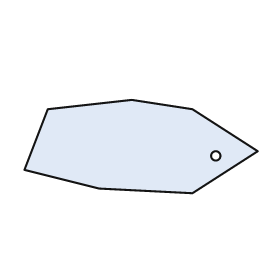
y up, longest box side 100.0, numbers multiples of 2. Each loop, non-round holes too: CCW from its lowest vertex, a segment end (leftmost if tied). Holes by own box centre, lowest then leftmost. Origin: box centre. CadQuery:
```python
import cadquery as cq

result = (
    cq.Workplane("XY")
    .moveTo(22.0, -20.0)
    .lineTo(50.0, -2.0)
    .lineTo(22.0, 16.0)
    .lineTo(-4.0, 20.0)
    .lineTo(-40.0, 16.0)
    .lineTo(-50.0, -10.0)
    .lineTo(-18.0, -18.0)
    .close()
    .moveTo(32.0, -4.0)
    .circle(2.0)
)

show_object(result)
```